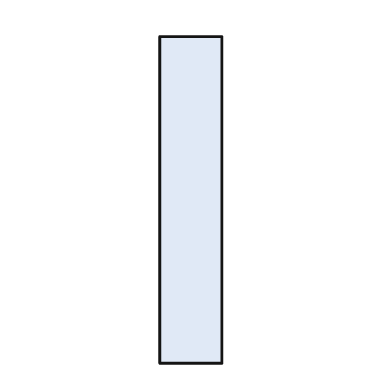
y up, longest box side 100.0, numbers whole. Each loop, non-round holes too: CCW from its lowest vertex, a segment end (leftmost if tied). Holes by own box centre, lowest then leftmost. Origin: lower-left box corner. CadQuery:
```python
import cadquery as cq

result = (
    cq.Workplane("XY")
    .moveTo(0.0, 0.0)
    .lineTo(19.0, 0.0)
    .lineTo(19.0, 100.0)
    .lineTo(0.0, 100.0)
    .close()
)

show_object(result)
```